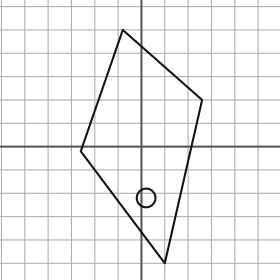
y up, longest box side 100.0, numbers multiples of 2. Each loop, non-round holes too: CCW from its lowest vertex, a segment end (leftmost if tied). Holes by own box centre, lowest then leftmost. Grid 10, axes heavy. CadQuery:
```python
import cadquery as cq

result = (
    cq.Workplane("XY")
    .moveTo(10.0, -50.0)
    .lineTo(26.0, 20.0)
    .lineTo(-8.0, 50.0)
    .lineTo(-26.0, -2.0)
    .close()
    .moveTo(2.0, -22.0)
    .circle(4.0)
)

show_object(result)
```